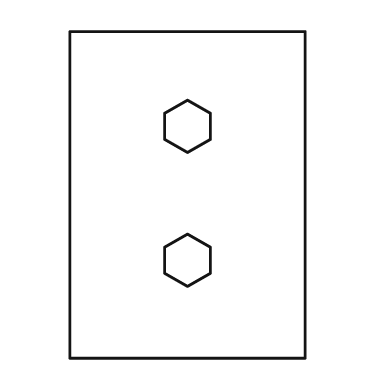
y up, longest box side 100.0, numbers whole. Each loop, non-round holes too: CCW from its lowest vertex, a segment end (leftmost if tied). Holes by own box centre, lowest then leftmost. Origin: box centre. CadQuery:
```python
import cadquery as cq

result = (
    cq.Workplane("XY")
    .moveTo(-36.0, -50.0)
    .lineTo(36.0, -50.0)
    .lineTo(36.0, 50.0)
    .lineTo(-36.0, 50.0)
    .close()
    .moveTo(0.0, -28.0)
    .lineTo(7.0, -24.0)
    .lineTo(7.0, -16.0)
    .lineTo(0.0, -12.0)
    .lineTo(-7.0, -16.0)
    .lineTo(-7.0, -24.0)
    .close()
    .moveTo(0.0, 13.0)
    .lineTo(7.0, 17.0)
    .lineTo(7.0, 25.0)
    .lineTo(0.0, 29.0)
    .lineTo(-7.0, 25.0)
    .lineTo(-7.0, 17.0)
    .close()
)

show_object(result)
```